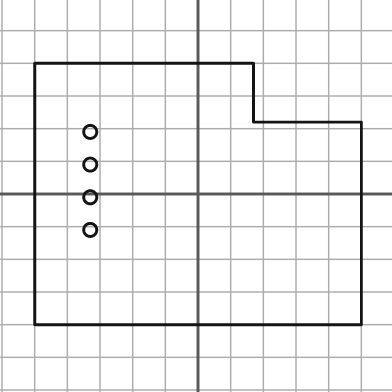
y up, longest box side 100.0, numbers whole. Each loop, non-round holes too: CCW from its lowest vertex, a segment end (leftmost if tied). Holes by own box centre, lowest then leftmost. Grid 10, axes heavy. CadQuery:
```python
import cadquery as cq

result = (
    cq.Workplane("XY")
    .moveTo(-50.0, -40.0)
    .lineTo(50.0, -40.0)
    .lineTo(50.0, 22.0)
    .lineTo(17.0, 22.0)
    .lineTo(17.0, 40.0)
    .lineTo(-50.0, 40.0)
    .close()
    .moveTo(-33.0, -11.0)
    .circle(2.0)
    .moveTo(-33.0, -1.0)
    .circle(2.0)
    .moveTo(-33.0, 9.0)
    .circle(2.0)
    .moveTo(-33.0, 19.0)
    .circle(2.0)
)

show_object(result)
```